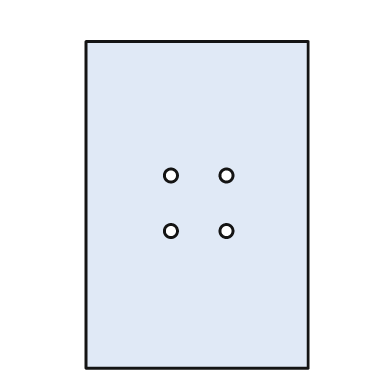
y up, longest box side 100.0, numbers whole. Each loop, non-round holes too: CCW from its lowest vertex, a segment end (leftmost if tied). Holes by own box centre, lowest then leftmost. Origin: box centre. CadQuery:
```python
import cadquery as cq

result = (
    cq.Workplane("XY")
    .moveTo(-34.0, -50.0)
    .lineTo(34.0, -50.0)
    .lineTo(34.0, 50.0)
    .lineTo(-34.0, 50.0)
    .close()
    .moveTo(-8.0, -8.0)
    .circle(2.0)
    .moveTo(9.0, -8.0)
    .circle(2.0)
    .moveTo(-8.0, 9.0)
    .circle(2.0)
    .moveTo(9.0, 9.0)
    .circle(2.0)
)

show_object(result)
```